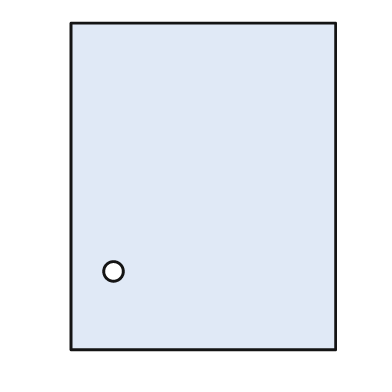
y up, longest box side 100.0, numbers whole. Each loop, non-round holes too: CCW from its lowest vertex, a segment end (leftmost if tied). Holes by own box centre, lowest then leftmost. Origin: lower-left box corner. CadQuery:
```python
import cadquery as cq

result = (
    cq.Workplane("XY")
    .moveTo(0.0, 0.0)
    .lineTo(81.0, 0.0)
    .lineTo(81.0, 100.0)
    .lineTo(0.0, 100.0)
    .close()
    .moveTo(13.0, 24.0)
    .circle(3.0)
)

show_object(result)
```